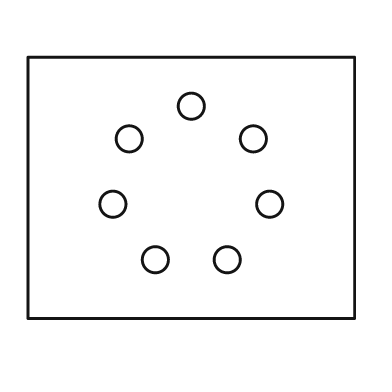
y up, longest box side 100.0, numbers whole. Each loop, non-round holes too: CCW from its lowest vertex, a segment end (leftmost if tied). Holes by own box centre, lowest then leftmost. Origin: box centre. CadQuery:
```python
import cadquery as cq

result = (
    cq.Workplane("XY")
    .moveTo(-50.0, -40.0)
    .lineTo(50.0, -40.0)
    .lineTo(50.0, 40.0)
    .lineTo(-50.0, 40.0)
    .close()
    .moveTo(-11.0, -22.0)
    .circle(4.0)
    .moveTo(11.0, -22.0)
    .circle(4.0)
    .moveTo(-24.0, -5.0)
    .circle(4.0)
    .moveTo(24.0, -5.0)
    .circle(4.0)
    .moveTo(-19.0, 15.0)
    .circle(4.0)
    .moveTo(19.0, 15.0)
    .circle(4.0)
    .moveTo(0.0, 25.0)
    .circle(4.0)
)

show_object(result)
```